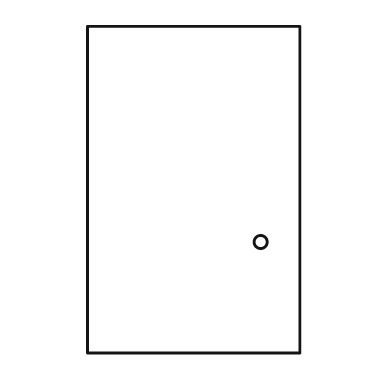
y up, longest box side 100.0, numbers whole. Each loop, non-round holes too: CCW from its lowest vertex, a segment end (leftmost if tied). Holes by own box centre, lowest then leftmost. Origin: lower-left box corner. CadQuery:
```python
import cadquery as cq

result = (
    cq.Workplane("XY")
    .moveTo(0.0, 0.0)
    .lineTo(65.0, 0.0)
    .lineTo(65.0, 100.0)
    .lineTo(0.0, 100.0)
    .close()
    .moveTo(53.0, 34.0)
    .circle(2.0)
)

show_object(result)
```